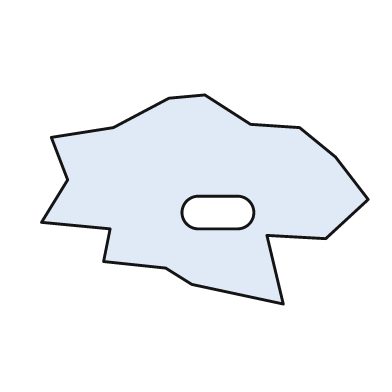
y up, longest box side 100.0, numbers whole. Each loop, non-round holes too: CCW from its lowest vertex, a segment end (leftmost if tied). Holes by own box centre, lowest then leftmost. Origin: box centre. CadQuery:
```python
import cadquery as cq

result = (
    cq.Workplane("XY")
    .moveTo(24.0, -32.0)
    .lineTo(19.0, -11.0)
    .lineTo(37.0, -12.0)
    .lineTo(50.0, 0.0)
    .lineTo(40.0, 13.0)
    .lineTo(29.0, 22.0)
    .lineTo(14.0, 23.0)
    .lineTo(0.0, 32.0)
    .lineTo(-11.0, 31.0)
    .lineTo(-28.0, 22.0)
    .lineTo(-47.0, 19.0)
    .lineTo(-42.0, 6.0)
    .lineTo(-50.0, -7.0)
    .lineTo(-29.0, -9.0)
    .lineTo(-31.0, -19.0)
    .lineTo(-12.0, -21.0)
    .lineTo(-4.0, -26.0)
    .close()
    .moveTo(-2.0, -9.0)
    .lineTo(10.0, -9.0)
    .threePointArc((15.0, -4.0), (10.0, 1.0))
    .lineTo(-2.0, 1.0)
    .threePointArc((-7.0, -4.0), (-2.0, -9.0))
    .close()
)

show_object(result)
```